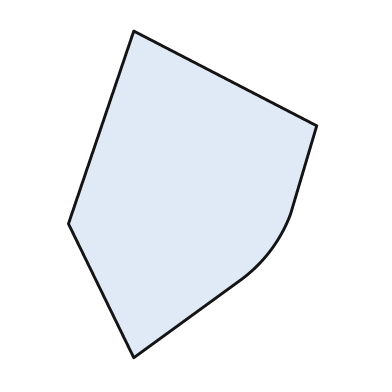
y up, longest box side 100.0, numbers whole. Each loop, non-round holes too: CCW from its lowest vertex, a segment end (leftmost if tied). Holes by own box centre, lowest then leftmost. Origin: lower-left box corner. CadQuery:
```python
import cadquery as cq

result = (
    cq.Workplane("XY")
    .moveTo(20.0, 0.0)
    .lineTo(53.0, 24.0)
    .threePointArc((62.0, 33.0), (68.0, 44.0))
    .lineTo(76.0, 71.0)
    .lineTo(20.0, 100.0)
    .lineTo(0.0, 41.0)
    .close()
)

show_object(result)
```